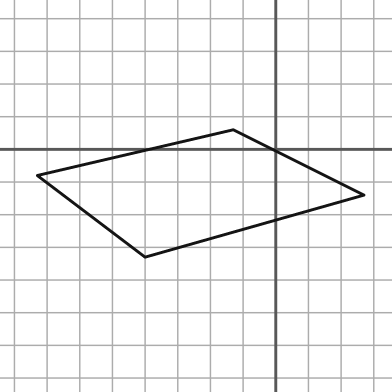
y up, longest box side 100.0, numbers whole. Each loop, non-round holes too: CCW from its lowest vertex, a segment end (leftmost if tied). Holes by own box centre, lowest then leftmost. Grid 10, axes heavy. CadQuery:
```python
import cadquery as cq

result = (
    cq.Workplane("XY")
    .moveTo(-40.0, -33.0)
    .lineTo(27.0, -14.0)
    .lineTo(-13.0, 6.0)
    .lineTo(-73.0, -8.0)
    .close()
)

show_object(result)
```